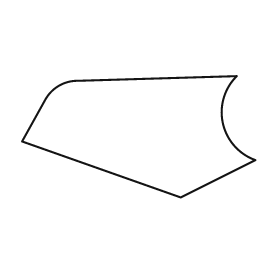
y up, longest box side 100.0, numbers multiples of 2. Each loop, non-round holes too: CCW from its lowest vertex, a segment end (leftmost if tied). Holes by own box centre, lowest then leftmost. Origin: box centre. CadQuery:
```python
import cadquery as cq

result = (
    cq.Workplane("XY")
    .moveTo(18.0, -26.0)
    .lineTo(50.0, -10.0)
    .threePointArc((36.0, 6.0), (42.0, 26.0))
    .lineTo(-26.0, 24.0)
    .threePointArc((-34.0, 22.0), (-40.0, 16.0))
    .lineTo(-50.0, -2.0)
    .close()
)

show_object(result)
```